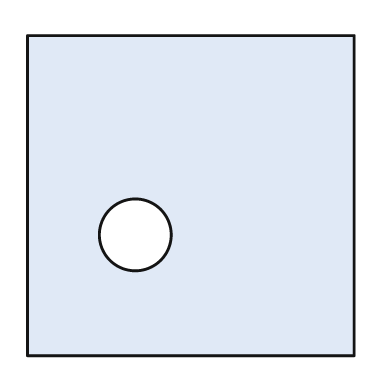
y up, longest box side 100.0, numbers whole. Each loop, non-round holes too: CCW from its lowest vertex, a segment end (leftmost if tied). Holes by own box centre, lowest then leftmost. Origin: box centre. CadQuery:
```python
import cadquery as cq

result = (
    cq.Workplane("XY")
    .moveTo(-50.0, -49.0)
    .lineTo(50.0, -49.0)
    .lineTo(50.0, 49.0)
    .lineTo(-50.0, 49.0)
    .close()
    .moveTo(-17.0, -12.0)
    .circle(11.0)
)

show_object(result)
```